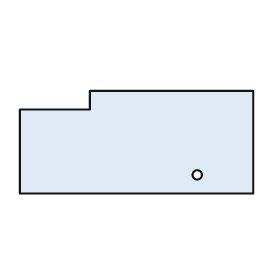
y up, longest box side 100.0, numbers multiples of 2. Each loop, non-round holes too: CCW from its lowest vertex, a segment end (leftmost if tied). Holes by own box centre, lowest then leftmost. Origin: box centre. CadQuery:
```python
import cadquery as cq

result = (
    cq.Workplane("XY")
    .moveTo(-50.0, -22.0)
    .lineTo(50.0, -22.0)
    .lineTo(50.0, 22.0)
    .lineTo(-20.0, 22.0)
    .lineTo(-20.0, 14.0)
    .lineTo(-50.0, 14.0)
    .close()
    .moveTo(26.0, -14.0)
    .circle(2.0)
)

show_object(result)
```